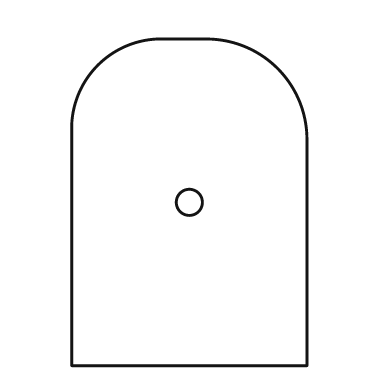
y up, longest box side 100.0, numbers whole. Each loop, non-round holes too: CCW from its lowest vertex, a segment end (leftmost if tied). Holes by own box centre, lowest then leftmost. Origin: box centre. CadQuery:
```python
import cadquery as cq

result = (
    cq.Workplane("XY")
    .moveTo(-36.0, -50.0)
    .lineTo(36.0, -50.0)
    .lineTo(36.0, 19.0)
    .threePointArc((27.0, 41.0), (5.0, 50.0))
    .lineTo(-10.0, 50.0)
    .threePointArc((-28.0, 42.0), (-36.0, 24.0))
    .close()
    .moveTo(0.0, 0.0)
    .circle(4.0)
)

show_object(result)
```